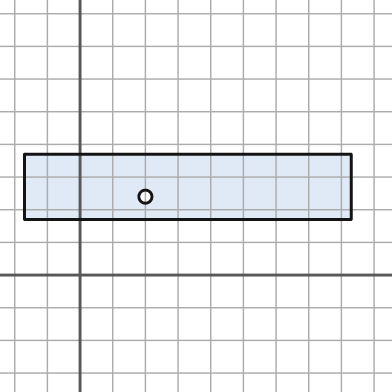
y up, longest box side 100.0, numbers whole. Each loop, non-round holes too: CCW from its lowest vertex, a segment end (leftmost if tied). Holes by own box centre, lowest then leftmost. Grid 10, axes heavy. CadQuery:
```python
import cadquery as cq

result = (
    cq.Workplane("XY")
    .moveTo(-17.0, 17.0)
    .lineTo(83.0, 17.0)
    .lineTo(83.0, 37.0)
    .lineTo(-17.0, 37.0)
    .close()
    .moveTo(20.0, 24.0)
    .circle(2.0)
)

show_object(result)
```